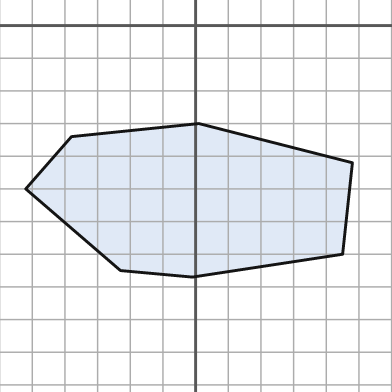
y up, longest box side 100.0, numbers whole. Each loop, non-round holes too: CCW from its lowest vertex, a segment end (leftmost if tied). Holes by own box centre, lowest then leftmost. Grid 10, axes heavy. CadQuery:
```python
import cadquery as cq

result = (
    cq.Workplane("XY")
    .moveTo(-1.0, -77.0)
    .lineTo(45.0, -70.0)
    .lineTo(48.0, -42.0)
    .lineTo(1.0, -30.0)
    .lineTo(-38.0, -34.0)
    .lineTo(-52.0, -50.0)
    .lineTo(-23.0, -75.0)
    .close()
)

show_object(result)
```